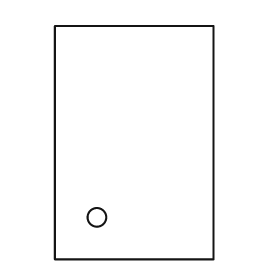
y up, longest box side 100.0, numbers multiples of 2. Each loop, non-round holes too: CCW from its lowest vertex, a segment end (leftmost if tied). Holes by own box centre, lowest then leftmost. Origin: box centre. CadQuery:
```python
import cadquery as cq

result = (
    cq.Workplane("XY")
    .moveTo(-34.0, -50.0)
    .lineTo(34.0, -50.0)
    .lineTo(34.0, 50.0)
    .lineTo(-34.0, 50.0)
    .close()
    .moveTo(-16.0, -32.0)
    .circle(4.0)
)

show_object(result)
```